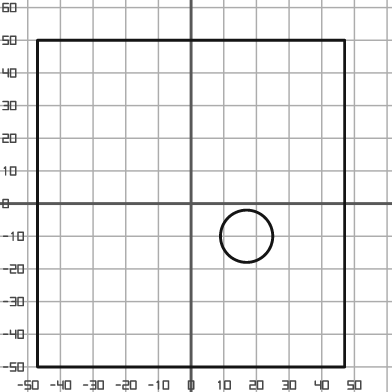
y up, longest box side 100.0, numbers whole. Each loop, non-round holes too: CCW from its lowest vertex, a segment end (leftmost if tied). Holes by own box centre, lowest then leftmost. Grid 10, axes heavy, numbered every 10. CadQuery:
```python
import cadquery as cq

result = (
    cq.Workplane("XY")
    .moveTo(-47.0, -50.0)
    .lineTo(47.0, -50.0)
    .lineTo(47.0, 50.0)
    .lineTo(-47.0, 50.0)
    .close()
    .moveTo(17.0, -10.0)
    .circle(8.0)
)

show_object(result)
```